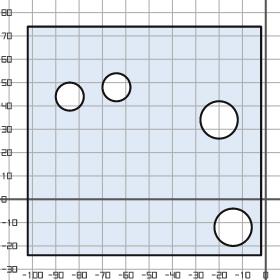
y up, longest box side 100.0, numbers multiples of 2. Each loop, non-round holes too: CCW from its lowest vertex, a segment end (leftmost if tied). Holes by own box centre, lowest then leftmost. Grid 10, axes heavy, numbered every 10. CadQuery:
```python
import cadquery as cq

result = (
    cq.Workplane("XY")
    .moveTo(-102.0, -24.0)
    .lineTo(-2.0, -24.0)
    .lineTo(-2.0, 74.0)
    .lineTo(-102.0, 74.0)
    .close()
    .moveTo(-14.0, -12.0)
    .circle(8.0)
    .moveTo(-20.0, 34.0)
    .circle(8.0)
    .moveTo(-84.0, 44.0)
    .circle(6.0)
    .moveTo(-64.0, 48.0)
    .circle(6.0)
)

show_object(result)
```